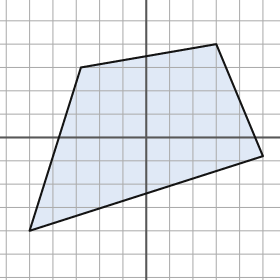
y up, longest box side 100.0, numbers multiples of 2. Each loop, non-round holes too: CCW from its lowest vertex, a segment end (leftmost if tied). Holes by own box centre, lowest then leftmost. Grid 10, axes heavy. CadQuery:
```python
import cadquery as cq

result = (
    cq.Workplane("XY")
    .moveTo(-50.0, -40.0)
    .lineTo(50.0, -8.0)
    .lineTo(30.0, 40.0)
    .lineTo(-28.0, 30.0)
    .close()
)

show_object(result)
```